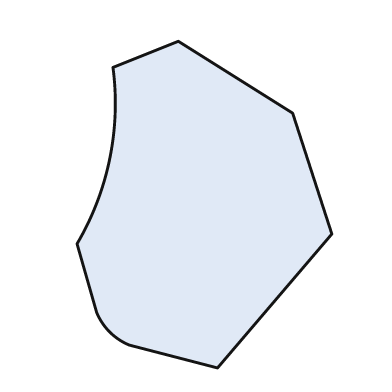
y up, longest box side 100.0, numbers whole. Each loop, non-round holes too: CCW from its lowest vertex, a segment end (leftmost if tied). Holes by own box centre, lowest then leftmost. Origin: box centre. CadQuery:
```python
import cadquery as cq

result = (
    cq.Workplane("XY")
    .moveTo(4.0, -50.0)
    .lineTo(39.0, -9.0)
    .lineTo(27.0, 28.0)
    .lineTo(-8.0, 50.0)
    .lineTo(-28.0, 42.0)
    .threePointArc((-29.0, 14.0), (-39.0, -12.0))
    .lineTo(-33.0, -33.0)
    .threePointArc((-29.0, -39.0), (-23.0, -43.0))
    .close()
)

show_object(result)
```